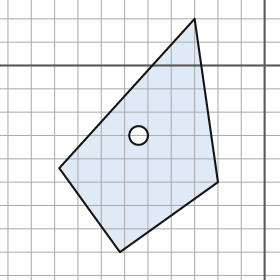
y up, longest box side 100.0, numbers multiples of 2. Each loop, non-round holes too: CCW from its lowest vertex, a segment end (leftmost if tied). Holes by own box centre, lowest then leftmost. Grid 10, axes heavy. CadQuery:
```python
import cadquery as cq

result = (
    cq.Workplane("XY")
    .moveTo(-62.0, -80.0)
    .lineTo(-20.0, -50.0)
    .lineTo(-30.0, 20.0)
    .lineTo(-88.0, -44.0)
    .close()
    .moveTo(-54.0, -30.0)
    .circle(4.0)
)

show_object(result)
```